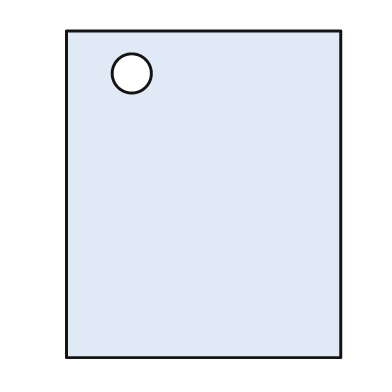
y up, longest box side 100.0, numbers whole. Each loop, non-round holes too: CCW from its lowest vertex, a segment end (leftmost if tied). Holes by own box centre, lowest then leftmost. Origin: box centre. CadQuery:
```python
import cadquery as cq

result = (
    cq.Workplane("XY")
    .moveTo(-42.0, -50.0)
    .lineTo(42.0, -50.0)
    .lineTo(42.0, 50.0)
    .lineTo(-42.0, 50.0)
    .close()
    .moveTo(-22.0, 37.0)
    .circle(6.0)
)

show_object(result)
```